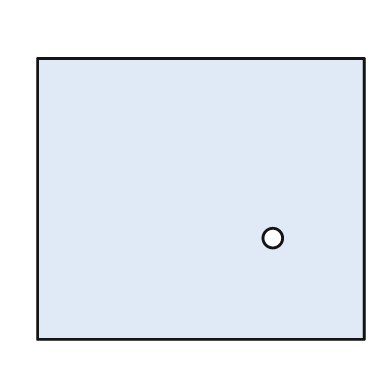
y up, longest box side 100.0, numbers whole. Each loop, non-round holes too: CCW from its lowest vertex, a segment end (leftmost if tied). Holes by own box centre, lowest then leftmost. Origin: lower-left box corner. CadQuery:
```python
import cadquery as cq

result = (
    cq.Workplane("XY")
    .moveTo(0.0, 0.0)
    .lineTo(100.0, 0.0)
    .lineTo(100.0, 86.0)
    .lineTo(0.0, 86.0)
    .close()
    .moveTo(72.0, 31.0)
    .circle(3.0)
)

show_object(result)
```